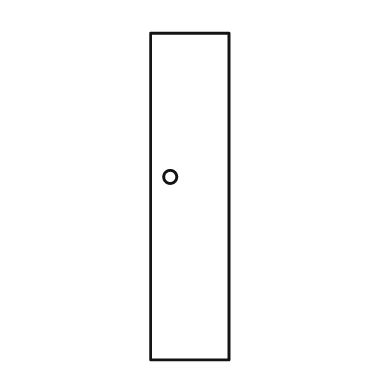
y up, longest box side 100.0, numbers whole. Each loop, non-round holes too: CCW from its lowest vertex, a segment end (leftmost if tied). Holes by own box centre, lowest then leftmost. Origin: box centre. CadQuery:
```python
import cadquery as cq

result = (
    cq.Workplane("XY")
    .moveTo(-12.0, -50.0)
    .lineTo(12.0, -50.0)
    .lineTo(12.0, 50.0)
    .lineTo(-12.0, 50.0)
    .close()
    .moveTo(-6.0, 6.0)
    .circle(2.0)
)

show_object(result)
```